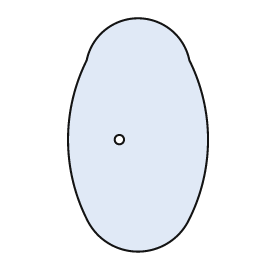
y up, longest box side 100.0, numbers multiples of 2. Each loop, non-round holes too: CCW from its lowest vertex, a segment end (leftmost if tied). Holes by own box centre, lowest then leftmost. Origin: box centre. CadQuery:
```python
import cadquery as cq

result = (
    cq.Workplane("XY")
    .moveTo(-22.0, -36.0)
    .threePointArc((0.0, -50.0), (22.0, -36.0))
    .threePointArc((30.0, -2.0), (22.0, 32.0))
    .threePointArc((0.0, 50.0), (-22.0, 32.0))
    .threePointArc((-30.0, -2.0), (-22.0, -36.0))
    .close()
    .moveTo(-8.0, -2.0)
    .circle(2.0)
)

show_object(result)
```